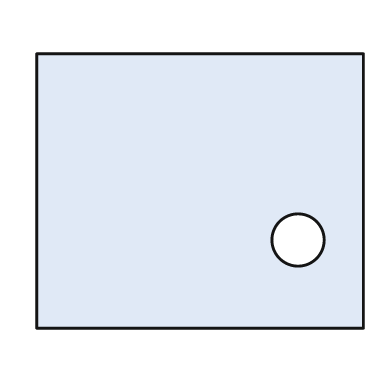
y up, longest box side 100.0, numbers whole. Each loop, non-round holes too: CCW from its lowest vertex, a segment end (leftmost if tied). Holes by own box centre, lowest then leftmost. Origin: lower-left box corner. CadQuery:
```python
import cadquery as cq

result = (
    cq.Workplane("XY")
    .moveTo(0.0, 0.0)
    .lineTo(100.0, 0.0)
    .lineTo(100.0, 84.0)
    .lineTo(0.0, 84.0)
    .close()
    .moveTo(80.0, 27.0)
    .circle(8.0)
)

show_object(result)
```